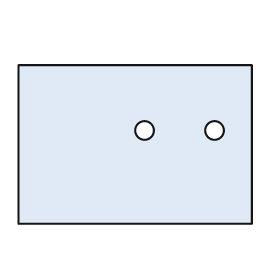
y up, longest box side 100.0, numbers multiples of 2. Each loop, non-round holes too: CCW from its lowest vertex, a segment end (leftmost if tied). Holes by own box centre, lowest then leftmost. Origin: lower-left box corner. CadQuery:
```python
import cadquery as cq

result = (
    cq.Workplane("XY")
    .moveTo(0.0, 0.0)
    .lineTo(100.0, 0.0)
    .lineTo(100.0, 68.0)
    .lineTo(0.0, 68.0)
    .close()
    .moveTo(54.0, 40.0)
    .circle(4.0)
    .moveTo(84.0, 40.0)
    .circle(4.0)
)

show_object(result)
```